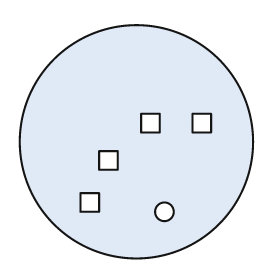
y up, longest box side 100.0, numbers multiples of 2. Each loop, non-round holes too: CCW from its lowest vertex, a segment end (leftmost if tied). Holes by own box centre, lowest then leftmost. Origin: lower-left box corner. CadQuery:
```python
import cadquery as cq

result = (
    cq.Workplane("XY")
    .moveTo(50.0, 50.0)
    .circle(50.0)
    .moveTo(62.0, 20.0)
    .circle(4.0)
    .moveTo(26.0, 20.0)
    .lineTo(34.0, 20.0)
    .lineTo(34.0, 28.0)
    .lineTo(26.0, 28.0)
    .close()
    .moveTo(34.0, 38.0)
    .lineTo(42.0, 38.0)
    .lineTo(42.0, 46.0)
    .lineTo(34.0, 46.0)
    .close()
    .moveTo(52.0, 54.0)
    .lineTo(60.0, 54.0)
    .lineTo(60.0, 62.0)
    .lineTo(52.0, 62.0)
    .close()
    .moveTo(74.0, 54.0)
    .lineTo(82.0, 54.0)
    .lineTo(82.0, 62.0)
    .lineTo(74.0, 62.0)
    .close()
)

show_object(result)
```